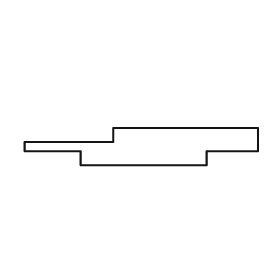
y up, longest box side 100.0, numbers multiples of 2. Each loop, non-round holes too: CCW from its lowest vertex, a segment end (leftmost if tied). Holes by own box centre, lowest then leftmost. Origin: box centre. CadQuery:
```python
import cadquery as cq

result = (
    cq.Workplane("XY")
    .moveTo(-26.0, -8.0)
    .lineTo(28.0, -8.0)
    .lineTo(28.0, -2.0)
    .lineTo(50.0, -2.0)
    .lineTo(50.0, 8.0)
    .lineTo(-12.0, 8.0)
    .lineTo(-12.0, 2.0)
    .lineTo(-50.0, 2.0)
    .lineTo(-50.0, -2.0)
    .lineTo(-26.0, -2.0)
    .close()
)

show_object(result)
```